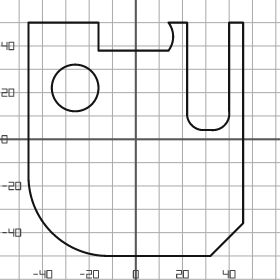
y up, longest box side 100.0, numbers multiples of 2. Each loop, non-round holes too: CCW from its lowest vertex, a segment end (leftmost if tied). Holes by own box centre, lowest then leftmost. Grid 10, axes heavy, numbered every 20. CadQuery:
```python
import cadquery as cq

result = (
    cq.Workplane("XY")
    .moveTo(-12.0, -50.0)
    .lineTo(32.0, -50.0)
    .lineTo(46.0, -36.0)
    .lineTo(46.0, 50.0)
    .lineTo(40.0, 50.0)
    .lineTo(40.0, 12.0)
    .threePointArc((38.0, 6.0), (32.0, 4.0))
    .lineTo(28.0, 4.0)
    .threePointArc((24.0, 6.0), (22.0, 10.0))
    .lineTo(22.0, 50.0)
    .lineTo(14.0, 50.0)
    .threePointArc((16.0, 44.0), (14.0, 38.0))
    .lineTo(-16.0, 38.0)
    .lineTo(-16.0, 50.0)
    .lineTo(-46.0, 50.0)
    .lineTo(-46.0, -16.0)
    .threePointArc((-36.0, -40.0), (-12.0, -50.0))
    .close()
    .moveTo(-26.0, 22.0)
    .circle(10.0)
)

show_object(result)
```